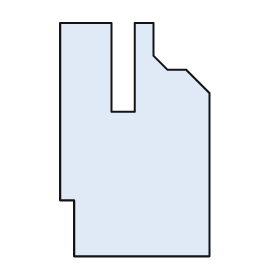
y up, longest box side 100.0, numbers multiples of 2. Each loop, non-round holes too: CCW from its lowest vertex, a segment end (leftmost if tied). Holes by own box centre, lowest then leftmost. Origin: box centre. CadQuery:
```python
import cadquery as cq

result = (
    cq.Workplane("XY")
    .moveTo(-26.0, -50.0)
    .lineTo(32.0, -50.0)
    .lineTo(32.0, 20.0)
    .lineTo(22.0, 30.0)
    .lineTo(14.0, 30.0)
    .lineTo(8.0, 36.0)
    .lineTo(8.0, 50.0)
    .lineTo(0.0, 50.0)
    .lineTo(0.0, 12.0)
    .lineTo(-10.0, 12.0)
    .lineTo(-10.0, 50.0)
    .lineTo(-32.0, 50.0)
    .lineTo(-32.0, -26.0)
    .lineTo(-26.0, -26.0)
    .close()
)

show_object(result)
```